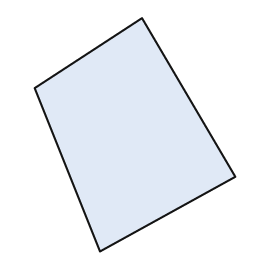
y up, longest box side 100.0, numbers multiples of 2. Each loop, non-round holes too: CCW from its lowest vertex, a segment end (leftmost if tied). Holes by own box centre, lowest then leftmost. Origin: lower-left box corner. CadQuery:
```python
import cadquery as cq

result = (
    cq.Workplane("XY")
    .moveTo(28.0, 0.0)
    .lineTo(86.0, 32.0)
    .lineTo(46.0, 100.0)
    .lineTo(0.0, 70.0)
    .close()
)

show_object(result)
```